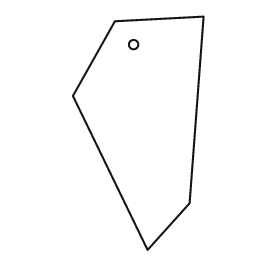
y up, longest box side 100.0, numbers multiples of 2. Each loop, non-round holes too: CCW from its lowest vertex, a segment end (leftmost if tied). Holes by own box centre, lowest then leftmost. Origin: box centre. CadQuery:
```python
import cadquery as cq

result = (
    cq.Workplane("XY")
    .moveTo(4.0, -50.0)
    .lineTo(22.0, -30.0)
    .lineTo(28.0, 50.0)
    .lineTo(-10.0, 48.0)
    .lineTo(-28.0, 16.0)
    .close()
    .moveTo(-2.0, 38.0)
    .circle(2.0)
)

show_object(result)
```